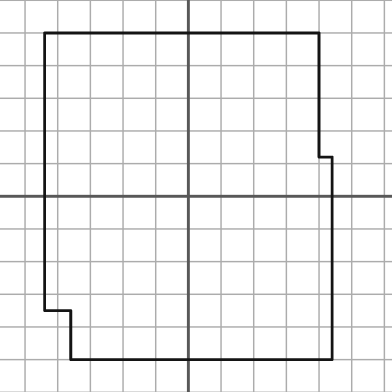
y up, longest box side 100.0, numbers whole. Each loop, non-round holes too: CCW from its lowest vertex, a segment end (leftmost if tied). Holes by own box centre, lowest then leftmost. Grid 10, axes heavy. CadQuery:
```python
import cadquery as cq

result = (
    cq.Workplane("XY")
    .moveTo(-36.0, -50.0)
    .lineTo(44.0, -50.0)
    .lineTo(44.0, 12.0)
    .lineTo(40.0, 12.0)
    .lineTo(40.0, 50.0)
    .lineTo(-44.0, 50.0)
    .lineTo(-44.0, -35.0)
    .lineTo(-36.0, -35.0)
    .close()
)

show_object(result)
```